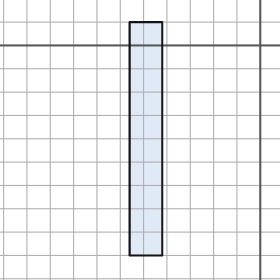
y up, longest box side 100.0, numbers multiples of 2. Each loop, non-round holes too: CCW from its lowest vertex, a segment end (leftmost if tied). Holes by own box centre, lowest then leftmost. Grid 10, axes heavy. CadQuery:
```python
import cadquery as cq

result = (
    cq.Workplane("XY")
    .moveTo(-56.0, -90.0)
    .lineTo(-42.0, -90.0)
    .lineTo(-42.0, 10.0)
    .lineTo(-56.0, 10.0)
    .close()
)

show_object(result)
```